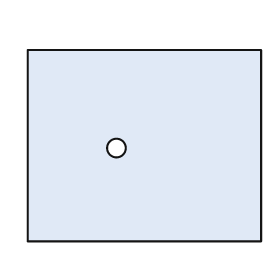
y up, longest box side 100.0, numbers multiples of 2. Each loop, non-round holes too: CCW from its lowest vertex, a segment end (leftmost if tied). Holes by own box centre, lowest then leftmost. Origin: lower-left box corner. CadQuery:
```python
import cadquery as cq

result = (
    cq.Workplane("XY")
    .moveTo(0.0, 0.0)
    .lineTo(100.0, 0.0)
    .lineTo(100.0, 82.0)
    .lineTo(0.0, 82.0)
    .close()
    .moveTo(38.0, 40.0)
    .circle(4.0)
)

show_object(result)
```